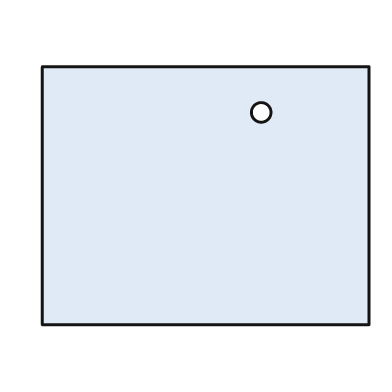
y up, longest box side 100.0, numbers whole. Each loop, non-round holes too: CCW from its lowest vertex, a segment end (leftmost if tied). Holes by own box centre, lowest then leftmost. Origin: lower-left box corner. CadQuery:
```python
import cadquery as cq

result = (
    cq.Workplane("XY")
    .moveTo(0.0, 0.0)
    .lineTo(100.0, 0.0)
    .lineTo(100.0, 79.0)
    .lineTo(0.0, 79.0)
    .close()
    .moveTo(67.0, 65.0)
    .circle(3.0)
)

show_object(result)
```